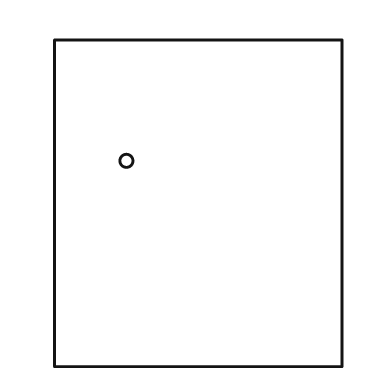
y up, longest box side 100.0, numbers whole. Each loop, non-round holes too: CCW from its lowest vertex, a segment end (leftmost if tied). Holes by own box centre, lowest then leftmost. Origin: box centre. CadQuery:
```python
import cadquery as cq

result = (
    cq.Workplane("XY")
    .moveTo(-44.0, -50.0)
    .lineTo(44.0, -50.0)
    .lineTo(44.0, 50.0)
    .lineTo(-44.0, 50.0)
    .close()
    .moveTo(-22.0, 13.0)
    .circle(2.0)
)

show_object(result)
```